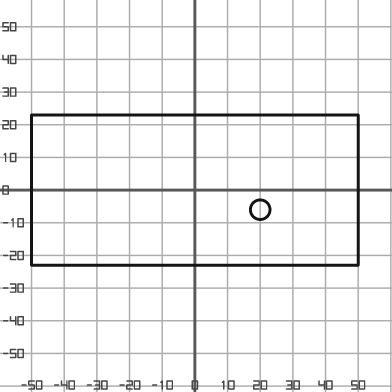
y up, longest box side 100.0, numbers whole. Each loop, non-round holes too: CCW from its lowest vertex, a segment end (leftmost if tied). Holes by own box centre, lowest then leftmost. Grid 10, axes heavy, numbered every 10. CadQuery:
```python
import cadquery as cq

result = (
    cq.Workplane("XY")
    .moveTo(-50.0, -23.0)
    .lineTo(50.0, -23.0)
    .lineTo(50.0, 23.0)
    .lineTo(-50.0, 23.0)
    .close()
    .moveTo(20.0, -6.0)
    .circle(3.0)
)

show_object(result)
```